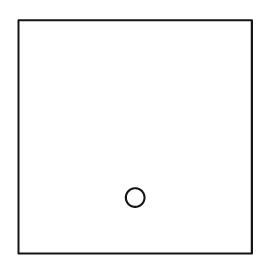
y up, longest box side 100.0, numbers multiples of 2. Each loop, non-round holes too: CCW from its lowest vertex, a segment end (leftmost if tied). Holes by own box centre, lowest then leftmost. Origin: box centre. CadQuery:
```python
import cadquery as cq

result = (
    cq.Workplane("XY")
    .moveTo(-50.0, -50.0)
    .lineTo(50.0, -50.0)
    .lineTo(50.0, 50.0)
    .lineTo(-50.0, 50.0)
    .close()
    .moveTo(0.0, -26.0)
    .circle(4.0)
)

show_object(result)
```